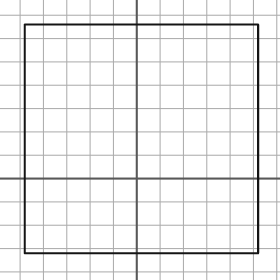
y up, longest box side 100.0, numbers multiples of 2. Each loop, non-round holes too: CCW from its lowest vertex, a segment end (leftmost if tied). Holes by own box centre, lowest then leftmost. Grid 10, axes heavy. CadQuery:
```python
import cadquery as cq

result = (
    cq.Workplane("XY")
    .moveTo(-48.0, -32.0)
    .lineTo(52.0, -32.0)
    .lineTo(52.0, 66.0)
    .lineTo(-48.0, 66.0)
    .close()
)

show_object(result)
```